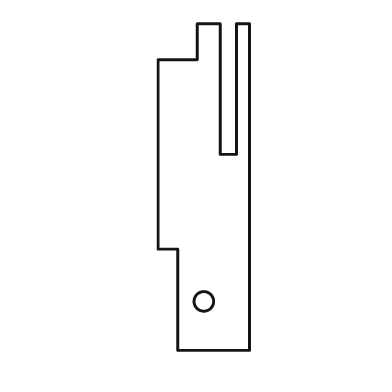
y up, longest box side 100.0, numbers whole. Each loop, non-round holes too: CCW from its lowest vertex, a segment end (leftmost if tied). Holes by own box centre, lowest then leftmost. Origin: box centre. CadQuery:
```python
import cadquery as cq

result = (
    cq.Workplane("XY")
    .moveTo(-8.0, -50.0)
    .lineTo(14.0, -50.0)
    .lineTo(14.0, 50.0)
    .lineTo(10.0, 50.0)
    .lineTo(10.0, 10.0)
    .lineTo(5.0, 10.0)
    .lineTo(5.0, 50.0)
    .lineTo(-2.0, 50.0)
    .lineTo(-2.0, 39.0)
    .lineTo(-14.0, 39.0)
    .lineTo(-14.0, -19.0)
    .lineTo(-8.0, -19.0)
    .close()
    .moveTo(0.0, -35.0)
    .circle(3.0)
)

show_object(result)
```